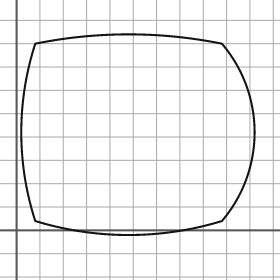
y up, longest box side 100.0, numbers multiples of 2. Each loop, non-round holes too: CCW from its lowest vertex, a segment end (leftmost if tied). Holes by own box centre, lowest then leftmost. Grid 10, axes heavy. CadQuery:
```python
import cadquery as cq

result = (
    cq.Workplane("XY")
    .moveTo(8.0, 4.0)
    .threePointArc((48.0, -2.0), (88.0, 4.0))
    .threePointArc((102.0, 42.0), (88.0, 80.0))
    .threePointArc((48.0, 84.0), (8.0, 80.0))
    .threePointArc((2.0, 42.0), (8.0, 4.0))
    .close()
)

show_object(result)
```